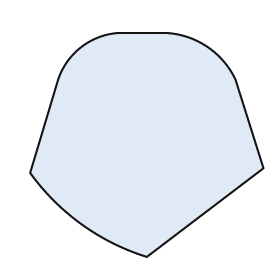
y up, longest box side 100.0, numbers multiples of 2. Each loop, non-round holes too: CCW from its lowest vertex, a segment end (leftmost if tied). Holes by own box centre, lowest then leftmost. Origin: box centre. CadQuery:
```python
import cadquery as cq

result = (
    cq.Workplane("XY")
    .moveTo(0.0, -48.0)
    .lineTo(50.0, -10.0)
    .lineTo(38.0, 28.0)
    .threePointArc((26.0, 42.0), (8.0, 48.0))
    .lineTo(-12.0, 48.0)
    .threePointArc((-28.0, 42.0), (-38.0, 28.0))
    .lineTo(-50.0, -12.0)
    .threePointArc((-28.0, -34.0), (0.0, -48.0))
    .close()
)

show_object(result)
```